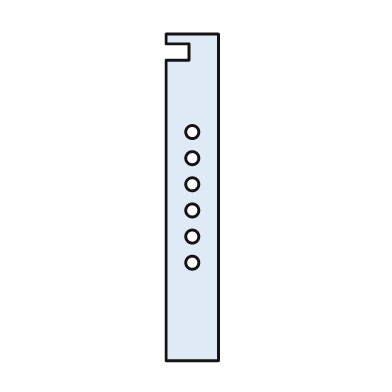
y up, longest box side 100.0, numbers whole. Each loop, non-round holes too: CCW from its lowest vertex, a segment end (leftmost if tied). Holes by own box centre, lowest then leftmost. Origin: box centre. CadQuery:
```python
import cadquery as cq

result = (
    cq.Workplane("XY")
    .moveTo(-8.0, -50.0)
    .lineTo(8.0, -50.0)
    .lineTo(8.0, 50.0)
    .lineTo(-8.0, 50.0)
    .lineTo(-8.0, 47.0)
    .lineTo(-1.0, 47.0)
    .lineTo(-1.0, 42.0)
    .lineTo(-8.0, 42.0)
    .close()
    .moveTo(0.0, -20.0)
    .circle(2.0)
    .moveTo(0.0, -12.0)
    .circle(2.0)
    .moveTo(0.0, -4.0)
    .circle(2.0)
    .moveTo(0.0, 4.0)
    .circle(2.0)
    .moveTo(0.0, 12.0)
    .circle(2.0)
    .moveTo(0.0, 20.0)
    .circle(2.0)
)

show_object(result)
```